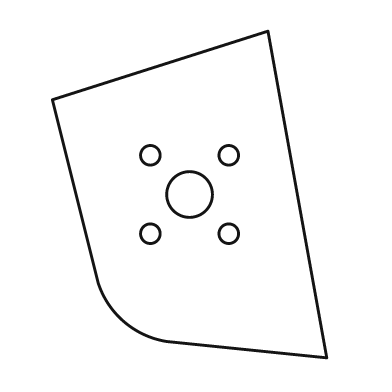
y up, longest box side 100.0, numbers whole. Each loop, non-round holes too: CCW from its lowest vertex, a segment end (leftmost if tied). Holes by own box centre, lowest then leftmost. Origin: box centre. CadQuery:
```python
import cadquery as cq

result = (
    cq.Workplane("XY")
    .moveTo(42.0, -50.0)
    .lineTo(24.0, 50.0)
    .lineTo(-42.0, 29.0)
    .lineTo(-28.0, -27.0)
    .threePointArc((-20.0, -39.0), (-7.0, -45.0))
    .close()
    .moveTo(-12.0, -12.0)
    .circle(3.0)
    .moveTo(12.0, -12.0)
    .circle(3.0)
    .moveTo(0.0, 0.0)
    .circle(7.0)
    .moveTo(-12.0, 12.0)
    .circle(3.0)
    .moveTo(12.0, 12.0)
    .circle(3.0)
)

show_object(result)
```